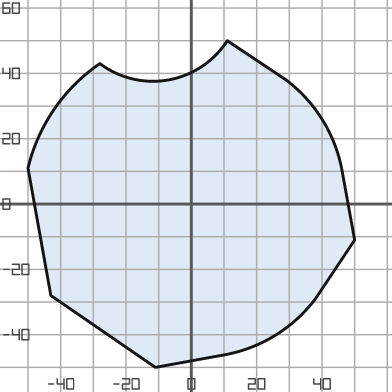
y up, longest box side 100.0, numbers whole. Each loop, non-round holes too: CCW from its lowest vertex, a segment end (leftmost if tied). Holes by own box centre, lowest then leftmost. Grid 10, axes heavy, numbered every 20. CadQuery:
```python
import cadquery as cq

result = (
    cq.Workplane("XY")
    .moveTo(-11.0, -50.0)
    .lineTo(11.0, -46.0)
    .threePointArc((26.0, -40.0), (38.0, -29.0))
    .lineTo(50.0, -11.0)
    .lineTo(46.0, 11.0)
    .threePointArc((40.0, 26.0), (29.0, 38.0))
    .lineTo(11.0, 50.0)
    .threePointArc((-7.0, 38.0), (-28.0, 43.0))
    .threePointArc((-42.0, 29.0), (-50.0, 11.0))
    .lineTo(-43.0, -28.0)
    .close()
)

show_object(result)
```